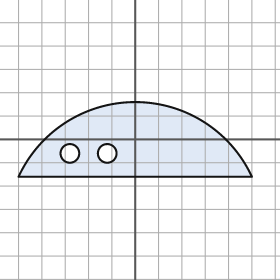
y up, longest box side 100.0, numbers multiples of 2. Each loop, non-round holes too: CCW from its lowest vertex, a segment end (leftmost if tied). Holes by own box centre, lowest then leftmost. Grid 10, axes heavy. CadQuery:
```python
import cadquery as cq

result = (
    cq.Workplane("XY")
    .moveTo(-50.0, -16.0)
    .lineTo(50.0, -16.0)
    .threePointArc((0.0, 16.0), (-50.0, -16.0))
    .close()
    .moveTo(-28.0, -6.0)
    .circle(4.0)
    .moveTo(-12.0, -6.0)
    .circle(4.0)
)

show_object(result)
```